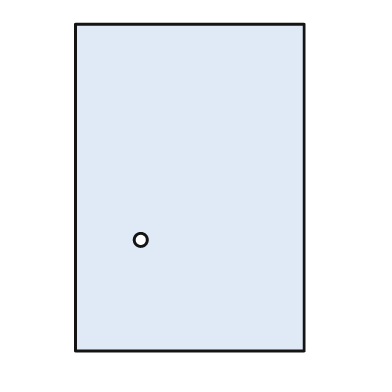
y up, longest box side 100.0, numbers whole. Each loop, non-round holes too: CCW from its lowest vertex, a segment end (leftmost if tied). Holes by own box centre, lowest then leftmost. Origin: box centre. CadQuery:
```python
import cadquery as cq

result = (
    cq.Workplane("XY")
    .moveTo(-35.0, -50.0)
    .lineTo(35.0, -50.0)
    .lineTo(35.0, 50.0)
    .lineTo(-35.0, 50.0)
    .close()
    .moveTo(-15.0, -16.0)
    .circle(2.0)
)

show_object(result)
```